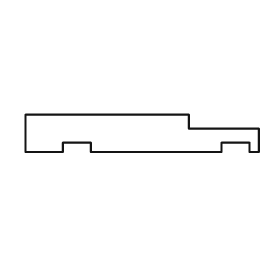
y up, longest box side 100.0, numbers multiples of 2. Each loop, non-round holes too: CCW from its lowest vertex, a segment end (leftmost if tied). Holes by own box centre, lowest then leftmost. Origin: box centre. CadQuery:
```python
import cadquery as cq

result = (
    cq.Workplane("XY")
    .moveTo(-50.0, -8.0)
    .lineTo(-34.0, -8.0)
    .lineTo(-34.0, -4.0)
    .lineTo(-22.0, -4.0)
    .lineTo(-22.0, -8.0)
    .lineTo(34.0, -8.0)
    .lineTo(34.0, -4.0)
    .lineTo(46.0, -4.0)
    .lineTo(46.0, -8.0)
    .lineTo(50.0, -8.0)
    .lineTo(50.0, 2.0)
    .lineTo(20.0, 2.0)
    .lineTo(20.0, 8.0)
    .lineTo(-50.0, 8.0)
    .close()
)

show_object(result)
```